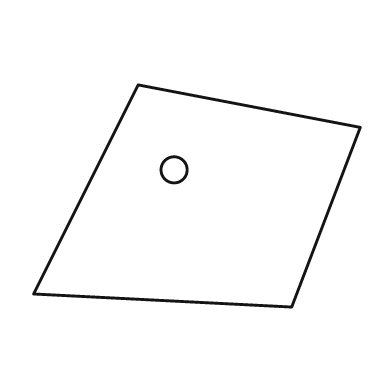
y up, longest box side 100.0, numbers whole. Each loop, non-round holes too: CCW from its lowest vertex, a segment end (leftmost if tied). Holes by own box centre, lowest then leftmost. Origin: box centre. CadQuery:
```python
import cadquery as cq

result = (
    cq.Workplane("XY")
    .moveTo(29.0, -34.0)
    .lineTo(50.0, 21.0)
    .lineTo(-18.0, 34.0)
    .lineTo(-50.0, -30.0)
    .close()
    .moveTo(-7.0, 8.0)
    .circle(4.0)
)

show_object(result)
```